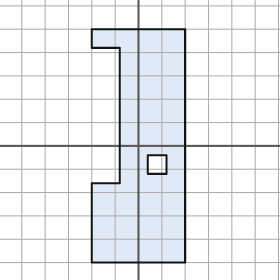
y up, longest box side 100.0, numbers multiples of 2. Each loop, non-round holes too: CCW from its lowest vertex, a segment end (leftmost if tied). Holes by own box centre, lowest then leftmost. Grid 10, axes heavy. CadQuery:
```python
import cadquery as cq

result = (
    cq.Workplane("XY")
    .moveTo(-20.0, -50.0)
    .lineTo(20.0, -50.0)
    .lineTo(20.0, 50.0)
    .lineTo(-20.0, 50.0)
    .lineTo(-20.0, 42.0)
    .lineTo(-8.0, 42.0)
    .lineTo(-8.0, -16.0)
    .lineTo(-20.0, -16.0)
    .close()
    .moveTo(4.0, -12.0)
    .lineTo(12.0, -12.0)
    .lineTo(12.0, -4.0)
    .lineTo(4.0, -4.0)
    .close()
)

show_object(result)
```